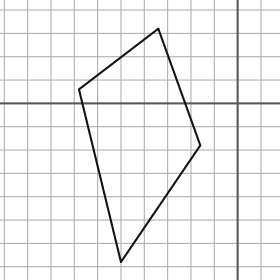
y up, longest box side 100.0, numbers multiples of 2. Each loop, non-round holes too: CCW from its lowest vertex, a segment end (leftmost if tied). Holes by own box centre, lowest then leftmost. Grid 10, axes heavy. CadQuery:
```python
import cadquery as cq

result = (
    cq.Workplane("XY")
    .moveTo(-50.0, -68.0)
    .lineTo(-16.0, -18.0)
    .lineTo(-34.0, 32.0)
    .lineTo(-68.0, 6.0)
    .close()
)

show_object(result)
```